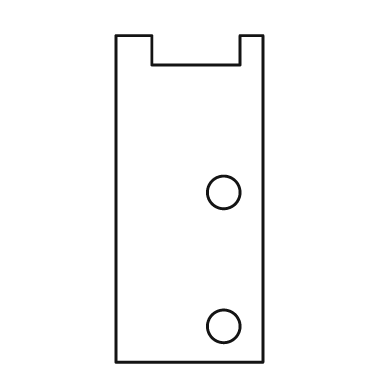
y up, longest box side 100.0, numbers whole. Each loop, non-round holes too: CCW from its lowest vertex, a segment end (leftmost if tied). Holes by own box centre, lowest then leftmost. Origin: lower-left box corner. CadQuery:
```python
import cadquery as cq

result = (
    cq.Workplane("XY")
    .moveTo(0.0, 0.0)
    .lineTo(45.0, 0.0)
    .lineTo(45.0, 100.0)
    .lineTo(38.0, 100.0)
    .lineTo(38.0, 91.0)
    .lineTo(11.0, 91.0)
    .lineTo(11.0, 100.0)
    .lineTo(0.0, 100.0)
    .close()
    .moveTo(33.0, 11.0)
    .circle(5.0)
    .moveTo(33.0, 52.0)
    .circle(5.0)
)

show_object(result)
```